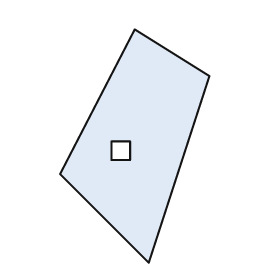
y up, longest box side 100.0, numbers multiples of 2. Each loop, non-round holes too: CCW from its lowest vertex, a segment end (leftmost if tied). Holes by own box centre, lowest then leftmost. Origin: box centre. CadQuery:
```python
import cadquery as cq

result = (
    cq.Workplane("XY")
    .moveTo(6.0, -50.0)
    .lineTo(32.0, 30.0)
    .lineTo(0.0, 50.0)
    .lineTo(-32.0, -12.0)
    .close()
    .moveTo(-10.0, -6.0)
    .lineTo(-2.0, -6.0)
    .lineTo(-2.0, 2.0)
    .lineTo(-10.0, 2.0)
    .close()
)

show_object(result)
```